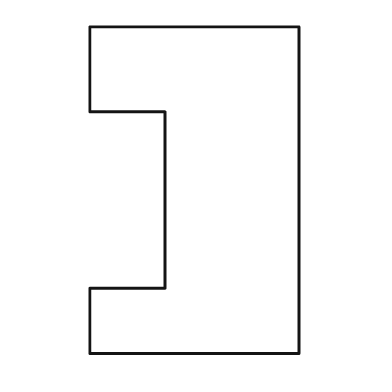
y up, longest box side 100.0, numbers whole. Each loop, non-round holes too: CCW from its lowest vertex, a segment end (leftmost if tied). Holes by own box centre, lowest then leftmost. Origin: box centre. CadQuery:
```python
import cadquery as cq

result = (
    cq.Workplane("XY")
    .moveTo(-32.0, -50.0)
    .lineTo(32.0, -50.0)
    .lineTo(32.0, 50.0)
    .lineTo(-32.0, 50.0)
    .lineTo(-32.0, 24.0)
    .lineTo(-9.0, 24.0)
    .lineTo(-9.0, -30.0)
    .lineTo(-32.0, -30.0)
    .close()
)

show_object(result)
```